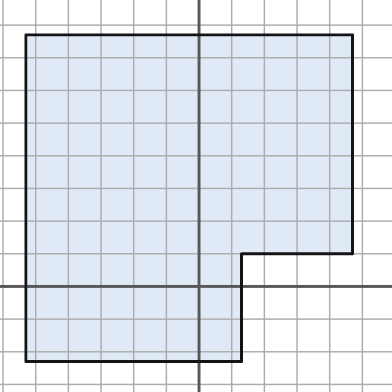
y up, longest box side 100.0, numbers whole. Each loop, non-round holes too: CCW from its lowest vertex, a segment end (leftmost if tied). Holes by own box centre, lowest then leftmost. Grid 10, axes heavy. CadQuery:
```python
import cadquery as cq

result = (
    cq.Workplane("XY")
    .moveTo(-53.0, -23.0)
    .lineTo(13.0, -23.0)
    .lineTo(13.0, 10.0)
    .lineTo(47.0, 10.0)
    .lineTo(47.0, 77.0)
    .lineTo(-53.0, 77.0)
    .close()
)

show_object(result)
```